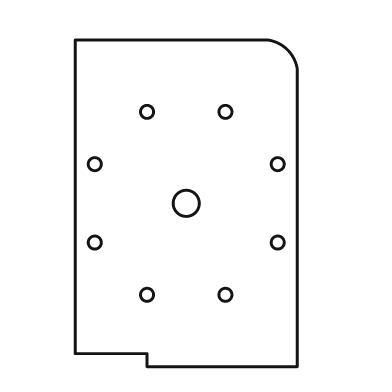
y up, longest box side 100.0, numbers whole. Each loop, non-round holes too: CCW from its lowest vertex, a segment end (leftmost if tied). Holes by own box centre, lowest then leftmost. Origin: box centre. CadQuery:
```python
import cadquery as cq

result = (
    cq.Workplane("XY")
    .moveTo(-12.0, -50.0)
    .lineTo(34.0, -50.0)
    .lineTo(34.0, 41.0)
    .threePointArc((31.0, 47.0), (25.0, 50.0))
    .lineTo(-34.0, 50.0)
    .lineTo(-34.0, -46.0)
    .lineTo(-12.0, -46.0)
    .close()
    .moveTo(-12.0, -28.0)
    .circle(2.0)
    .moveTo(12.0, -28.0)
    .circle(2.0)
    .moveTo(-28.0, -12.0)
    .circle(2.0)
    .moveTo(28.0, -12.0)
    .circle(2.0)
    .moveTo(0.0, 0.0)
    .circle(4.0)
    .moveTo(-28.0, 12.0)
    .circle(2.0)
    .moveTo(28.0, 12.0)
    .circle(2.0)
    .moveTo(-12.0, 28.0)
    .circle(2.0)
    .moveTo(12.0, 28.0)
    .circle(2.0)
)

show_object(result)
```